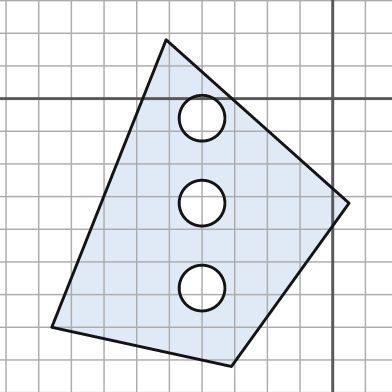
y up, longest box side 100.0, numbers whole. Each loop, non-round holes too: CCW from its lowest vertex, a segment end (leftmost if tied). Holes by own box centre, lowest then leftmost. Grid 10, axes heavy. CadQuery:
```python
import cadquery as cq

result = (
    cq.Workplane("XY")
    .moveTo(-31.0, -82.0)
    .lineTo(5.0, -32.0)
    .lineTo(-51.0, 18.0)
    .lineTo(-86.0, -70.0)
    .close()
    .moveTo(-40.0, -58.0)
    .circle(7.0)
    .moveTo(-40.0, -32.0)
    .circle(7.0)
    .moveTo(-40.0, -6.0)
    .circle(7.0)
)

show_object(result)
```